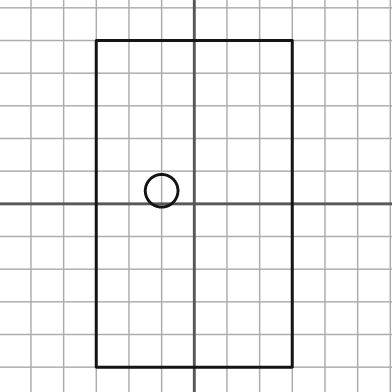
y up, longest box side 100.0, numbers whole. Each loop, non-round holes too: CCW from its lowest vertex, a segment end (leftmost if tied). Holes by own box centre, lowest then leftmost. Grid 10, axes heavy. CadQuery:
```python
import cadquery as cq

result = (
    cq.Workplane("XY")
    .moveTo(-30.0, -50.0)
    .lineTo(30.0, -50.0)
    .lineTo(30.0, 50.0)
    .lineTo(-30.0, 50.0)
    .close()
    .moveTo(-10.0, 4.0)
    .circle(5.0)
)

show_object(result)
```